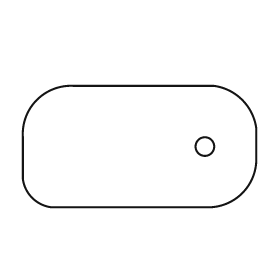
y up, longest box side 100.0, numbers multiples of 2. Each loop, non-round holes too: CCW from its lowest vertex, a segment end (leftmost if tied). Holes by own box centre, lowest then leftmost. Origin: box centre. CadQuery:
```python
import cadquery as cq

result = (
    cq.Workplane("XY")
    .moveTo(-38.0, -26.0)
    .lineTo(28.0, -26.0)
    .threePointArc((44.0, -20.0), (50.0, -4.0))
    .lineTo(50.0, 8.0)
    .threePointArc((44.0, 20.0), (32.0, 26.0))
    .lineTo(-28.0, 26.0)
    .threePointArc((-44.0, 20.0), (-50.0, 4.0))
    .lineTo(-50.0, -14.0)
    .threePointArc((-46.0, -22.0), (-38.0, -26.0))
    .close()
    .moveTo(28.0, 0.0)
    .circle(4.0)
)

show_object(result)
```